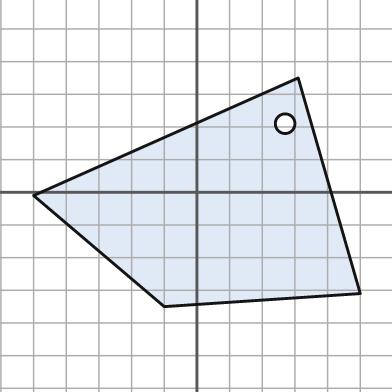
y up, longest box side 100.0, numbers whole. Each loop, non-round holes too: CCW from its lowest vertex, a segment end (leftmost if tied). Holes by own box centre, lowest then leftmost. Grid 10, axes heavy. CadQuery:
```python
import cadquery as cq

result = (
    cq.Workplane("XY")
    .moveTo(-10.0, -35.0)
    .lineTo(50.0, -31.0)
    .lineTo(31.0, 35.0)
    .lineTo(-50.0, -1.0)
    .close()
    .moveTo(27.0, 21.0)
    .circle(3.0)
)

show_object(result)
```